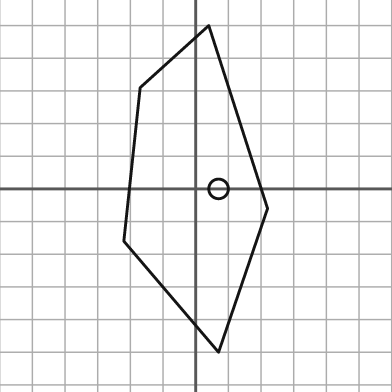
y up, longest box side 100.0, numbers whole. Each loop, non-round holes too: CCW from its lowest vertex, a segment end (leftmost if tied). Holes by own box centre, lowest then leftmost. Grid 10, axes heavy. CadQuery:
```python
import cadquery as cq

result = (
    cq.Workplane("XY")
    .moveTo(7.0, -50.0)
    .lineTo(22.0, -6.0)
    .lineTo(4.0, 50.0)
    .lineTo(-17.0, 31.0)
    .lineTo(-22.0, -16.0)
    .close()
    .moveTo(7.0, 0.0)
    .circle(3.0)
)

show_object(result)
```